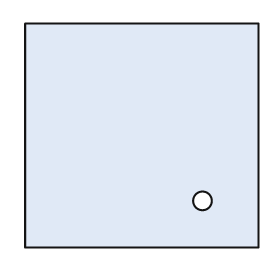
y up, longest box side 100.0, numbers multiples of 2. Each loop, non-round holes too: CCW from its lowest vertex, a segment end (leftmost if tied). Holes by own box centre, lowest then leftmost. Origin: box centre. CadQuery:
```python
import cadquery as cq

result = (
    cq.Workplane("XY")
    .moveTo(-50.0, -48.0)
    .lineTo(50.0, -48.0)
    .lineTo(50.0, 48.0)
    .lineTo(-50.0, 48.0)
    .close()
    .moveTo(26.0, -28.0)
    .circle(4.0)
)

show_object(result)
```